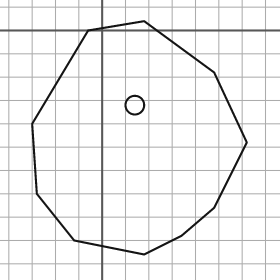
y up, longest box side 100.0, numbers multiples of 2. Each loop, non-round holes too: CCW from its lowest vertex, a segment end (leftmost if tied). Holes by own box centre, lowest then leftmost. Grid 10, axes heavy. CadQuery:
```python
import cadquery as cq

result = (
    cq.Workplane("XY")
    .moveTo(18.0, -96.0)
    .lineTo(34.0, -88.0)
    .lineTo(48.0, -76.0)
    .lineTo(62.0, -48.0)
    .lineTo(48.0, -18.0)
    .lineTo(18.0, 4.0)
    .lineTo(-6.0, 0.0)
    .lineTo(-30.0, -40.0)
    .lineTo(-28.0, -70.0)
    .lineTo(-12.0, -90.0)
    .close()
    .moveTo(14.0, -32.0)
    .circle(4.0)
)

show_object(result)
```